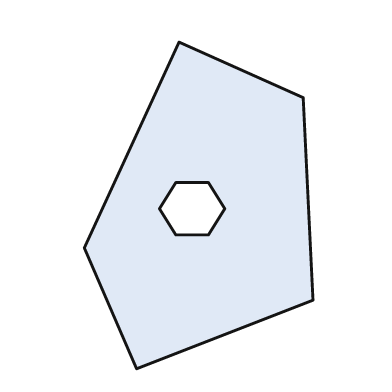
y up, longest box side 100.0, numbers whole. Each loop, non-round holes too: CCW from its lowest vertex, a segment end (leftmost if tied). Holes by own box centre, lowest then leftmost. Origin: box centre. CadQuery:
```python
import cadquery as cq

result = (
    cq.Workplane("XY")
    .moveTo(-19.0, -50.0)
    .lineTo(35.0, -29.0)
    .lineTo(32.0, 33.0)
    .lineTo(-6.0, 50.0)
    .lineTo(-35.0, -13.0)
    .close()
    .moveTo(-7.0, -9.0)
    .lineTo(3.0, -9.0)
    .lineTo(8.0, -1.0)
    .lineTo(3.0, 7.0)
    .lineTo(-7.0, 7.0)
    .lineTo(-12.0, -1.0)
    .close()
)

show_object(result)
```